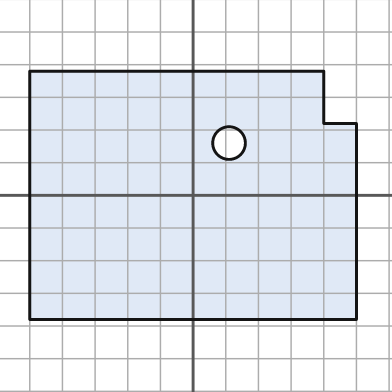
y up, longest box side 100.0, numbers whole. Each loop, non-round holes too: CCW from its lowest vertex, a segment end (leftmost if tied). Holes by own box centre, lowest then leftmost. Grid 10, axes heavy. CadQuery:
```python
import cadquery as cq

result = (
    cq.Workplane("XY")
    .moveTo(-50.0, -38.0)
    .lineTo(50.0, -38.0)
    .lineTo(50.0, 22.0)
    .lineTo(40.0, 22.0)
    .lineTo(40.0, 38.0)
    .lineTo(-50.0, 38.0)
    .close()
    .moveTo(11.0, 16.0)
    .circle(5.0)
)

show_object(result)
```